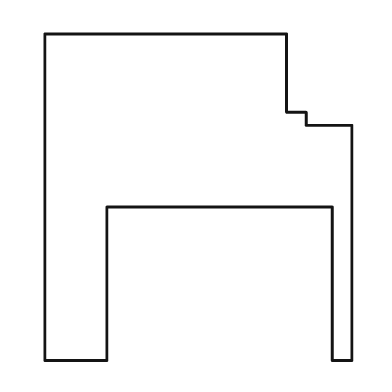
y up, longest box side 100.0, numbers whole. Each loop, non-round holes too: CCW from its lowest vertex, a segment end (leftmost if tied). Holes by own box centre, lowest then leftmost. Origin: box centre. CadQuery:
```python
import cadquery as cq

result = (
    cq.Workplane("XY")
    .moveTo(-47.0, -50.0)
    .lineTo(-28.0, -50.0)
    .lineTo(-28.0, -3.0)
    .lineTo(41.0, -3.0)
    .lineTo(41.0, -50.0)
    .lineTo(47.0, -50.0)
    .lineTo(47.0, 22.0)
    .lineTo(33.0, 22.0)
    .lineTo(33.0, 26.0)
    .lineTo(27.0, 26.0)
    .lineTo(27.0, 50.0)
    .lineTo(-47.0, 50.0)
    .close()
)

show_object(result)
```